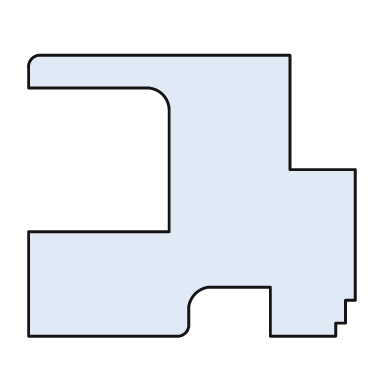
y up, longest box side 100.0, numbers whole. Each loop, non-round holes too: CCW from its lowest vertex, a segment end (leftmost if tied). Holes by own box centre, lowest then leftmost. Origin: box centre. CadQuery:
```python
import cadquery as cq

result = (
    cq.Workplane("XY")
    .moveTo(-50.0, -43.0)
    .lineTo(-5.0, -43.0)
    .threePointArc((-2.0, -42.0), (-1.0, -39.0))
    .lineTo(-1.0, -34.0)
    .threePointArc((1.0, -30.0), (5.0, -28.0))
    .lineTo(24.0, -28.0)
    .lineTo(24.0, -43.0)
    .lineTo(44.0, -43.0)
    .lineTo(44.0, -39.0)
    .lineTo(47.0, -39.0)
    .lineTo(47.0, -32.0)
    .lineTo(50.0, -32.0)
    .lineTo(50.0, 8.0)
    .lineTo(30.0, 8.0)
    .lineTo(30.0, 43.0)
    .lineTo(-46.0, 43.0)
    .threePointArc((-49.0, 42.0), (-50.0, 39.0))
    .lineTo(-50.0, 33.0)
    .lineTo(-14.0, 33.0)
    .threePointArc((-9.0, 31.0), (-7.0, 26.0))
    .lineTo(-7.0, -11.0)
    .lineTo(-50.0, -11.0)
    .close()
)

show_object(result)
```